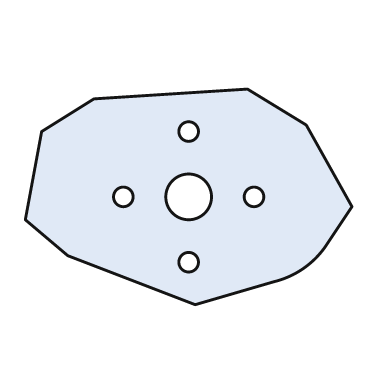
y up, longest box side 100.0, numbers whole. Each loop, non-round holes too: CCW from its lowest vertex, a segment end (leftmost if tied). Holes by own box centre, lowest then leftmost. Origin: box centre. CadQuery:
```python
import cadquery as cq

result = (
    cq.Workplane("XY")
    .moveTo(2.0, -33.0)
    .lineTo(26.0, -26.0)
    .threePointArc((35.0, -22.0), (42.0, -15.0))
    .lineTo(50.0, -3.0)
    .lineTo(36.0, 22.0)
    .lineTo(18.0, 33.0)
    .lineTo(-29.0, 30.0)
    .lineTo(-45.0, 20.0)
    .lineTo(-50.0, -7.0)
    .lineTo(-37.0, -18.0)
    .close()
    .moveTo(0.0, -20.0)
    .circle(3.0)
    .moveTo(-20.0, 0.0)
    .circle(3.0)
    .moveTo(0.0, 0.0)
    .circle(7.0)
    .moveTo(20.0, 0.0)
    .circle(3.0)
    .moveTo(0.0, 20.0)
    .circle(3.0)
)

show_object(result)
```